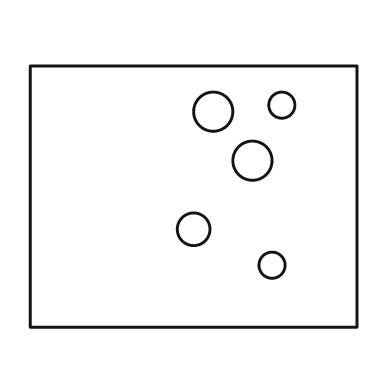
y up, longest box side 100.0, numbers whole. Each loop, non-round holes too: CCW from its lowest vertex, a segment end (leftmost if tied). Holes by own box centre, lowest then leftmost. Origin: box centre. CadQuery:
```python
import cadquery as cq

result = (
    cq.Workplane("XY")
    .moveTo(-50.0, -40.0)
    .lineTo(50.0, -40.0)
    .lineTo(50.0, 40.0)
    .lineTo(-50.0, 40.0)
    .close()
    .moveTo(24.0, -21.0)
    .circle(4.0)
    .moveTo(0.0, -10.0)
    .circle(5.0)
    .moveTo(18.0, 11.0)
    .circle(6.0)
    .moveTo(6.0, 26.0)
    .circle(6.0)
    .moveTo(27.0, 28.0)
    .circle(4.0)
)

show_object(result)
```